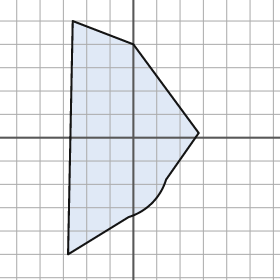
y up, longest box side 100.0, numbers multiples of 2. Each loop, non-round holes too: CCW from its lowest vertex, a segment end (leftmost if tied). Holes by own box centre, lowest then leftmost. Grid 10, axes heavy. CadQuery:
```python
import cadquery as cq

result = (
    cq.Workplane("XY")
    .moveTo(-28.0, -50.0)
    .lineTo(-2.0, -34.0)
    .threePointArc((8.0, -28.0), (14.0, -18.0))
    .lineTo(28.0, 2.0)
    .lineTo(0.0, 40.0)
    .lineTo(-26.0, 50.0)
    .close()
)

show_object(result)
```